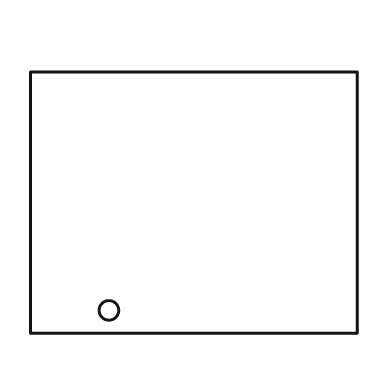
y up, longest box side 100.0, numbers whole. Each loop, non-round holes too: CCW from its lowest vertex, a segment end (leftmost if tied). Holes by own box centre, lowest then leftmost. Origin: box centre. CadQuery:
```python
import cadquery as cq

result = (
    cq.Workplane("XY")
    .moveTo(-50.0, -40.0)
    .lineTo(50.0, -40.0)
    .lineTo(50.0, 40.0)
    .lineTo(-50.0, 40.0)
    .close()
    .moveTo(-26.0, -33.0)
    .circle(3.0)
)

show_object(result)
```